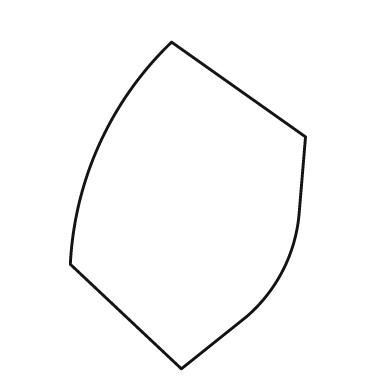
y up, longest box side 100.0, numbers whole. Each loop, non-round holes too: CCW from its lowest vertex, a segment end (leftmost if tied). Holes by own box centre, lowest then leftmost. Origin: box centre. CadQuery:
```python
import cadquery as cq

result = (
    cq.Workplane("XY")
    .moveTo(-2.0, -50.0)
    .lineTo(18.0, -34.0)
    .threePointArc((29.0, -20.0), (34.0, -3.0))
    .lineTo(36.0, 21.0)
    .lineTo(-5.0, 50.0)
    .threePointArc((-27.0, 19.0), (-36.0, -18.0))
    .close()
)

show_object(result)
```